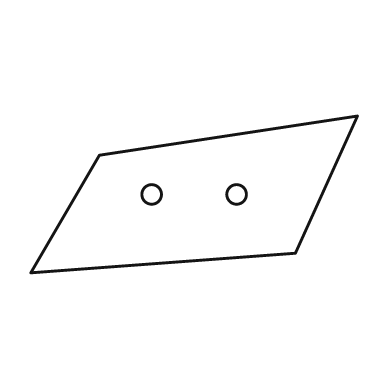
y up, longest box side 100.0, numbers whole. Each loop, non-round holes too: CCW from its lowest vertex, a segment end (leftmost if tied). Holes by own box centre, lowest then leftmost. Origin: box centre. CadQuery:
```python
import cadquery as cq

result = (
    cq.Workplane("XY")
    .moveTo(-50.0, -24.0)
    .lineTo(31.0, -18.0)
    .lineTo(50.0, 24.0)
    .lineTo(-29.0, 12.0)
    .close()
    .moveTo(-13.0, 0.0)
    .circle(3.0)
    .moveTo(13.0, 0.0)
    .circle(3.0)
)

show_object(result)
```